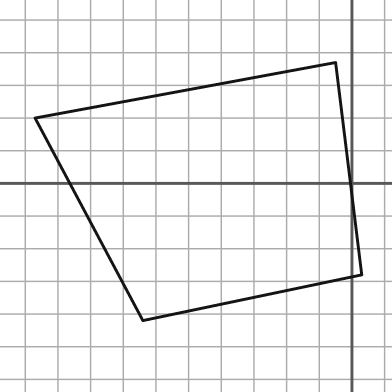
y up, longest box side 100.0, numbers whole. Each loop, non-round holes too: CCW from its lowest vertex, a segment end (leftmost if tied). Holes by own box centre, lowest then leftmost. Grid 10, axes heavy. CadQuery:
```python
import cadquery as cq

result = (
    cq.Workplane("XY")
    .moveTo(-64.0, -42.0)
    .lineTo(3.0, -28.0)
    .lineTo(-5.0, 37.0)
    .lineTo(-97.0, 20.0)
    .close()
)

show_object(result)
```